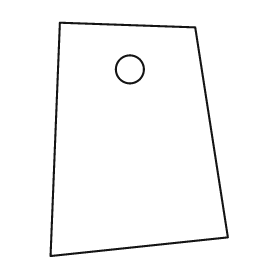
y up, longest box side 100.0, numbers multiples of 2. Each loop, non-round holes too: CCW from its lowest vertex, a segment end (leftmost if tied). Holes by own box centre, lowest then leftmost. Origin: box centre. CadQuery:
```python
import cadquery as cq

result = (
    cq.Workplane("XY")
    .moveTo(-38.0, -50.0)
    .lineTo(38.0, -42.0)
    .lineTo(24.0, 48.0)
    .lineTo(-34.0, 50.0)
    .close()
    .moveTo(-4.0, 30.0)
    .circle(6.0)
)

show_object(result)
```